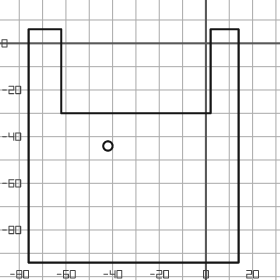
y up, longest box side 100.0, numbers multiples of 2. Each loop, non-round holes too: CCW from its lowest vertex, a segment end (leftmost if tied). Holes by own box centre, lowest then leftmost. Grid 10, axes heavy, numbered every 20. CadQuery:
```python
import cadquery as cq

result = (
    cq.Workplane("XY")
    .moveTo(-76.0, -94.0)
    .lineTo(14.0, -94.0)
    .lineTo(14.0, 6.0)
    .lineTo(2.0, 6.0)
    .lineTo(2.0, -30.0)
    .lineTo(-62.0, -30.0)
    .lineTo(-62.0, 6.0)
    .lineTo(-76.0, 6.0)
    .close()
    .moveTo(-42.0, -44.0)
    .circle(2.0)
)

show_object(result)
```